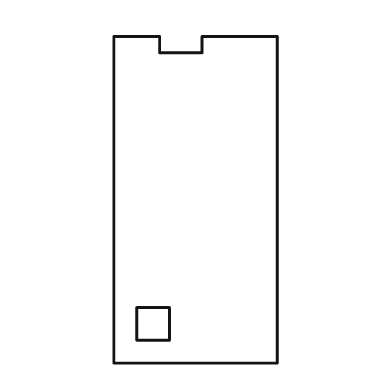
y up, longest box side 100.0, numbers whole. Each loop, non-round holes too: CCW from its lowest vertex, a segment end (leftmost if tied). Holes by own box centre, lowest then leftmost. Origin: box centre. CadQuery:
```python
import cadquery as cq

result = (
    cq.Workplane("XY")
    .moveTo(-25.0, -50.0)
    .lineTo(25.0, -50.0)
    .lineTo(25.0, 50.0)
    .lineTo(2.0, 50.0)
    .lineTo(2.0, 45.0)
    .lineTo(-11.0, 45.0)
    .lineTo(-11.0, 50.0)
    .lineTo(-25.0, 50.0)
    .close()
    .moveTo(-18.0, -43.0)
    .lineTo(-8.0, -43.0)
    .lineTo(-8.0, -33.0)
    .lineTo(-18.0, -33.0)
    .close()
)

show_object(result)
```